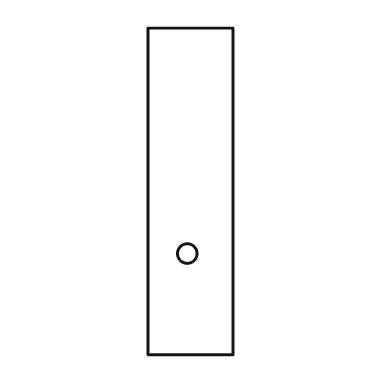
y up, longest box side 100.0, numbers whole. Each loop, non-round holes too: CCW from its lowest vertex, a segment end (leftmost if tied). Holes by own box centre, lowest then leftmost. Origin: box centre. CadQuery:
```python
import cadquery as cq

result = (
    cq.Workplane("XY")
    .moveTo(-13.0, -50.0)
    .lineTo(13.0, -50.0)
    .lineTo(13.0, 50.0)
    .lineTo(-13.0, 50.0)
    .close()
    .moveTo(-1.0, -19.0)
    .circle(3.0)
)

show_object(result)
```